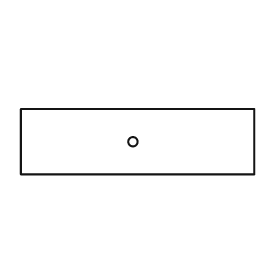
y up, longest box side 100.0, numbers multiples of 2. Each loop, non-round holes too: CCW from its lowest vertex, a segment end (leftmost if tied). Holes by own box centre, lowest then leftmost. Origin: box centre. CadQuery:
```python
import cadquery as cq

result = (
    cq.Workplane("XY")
    .moveTo(-50.0, -14.0)
    .lineTo(50.0, -14.0)
    .lineTo(50.0, 14.0)
    .lineTo(-50.0, 14.0)
    .close()
    .moveTo(-2.0, 0.0)
    .circle(2.0)
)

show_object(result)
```